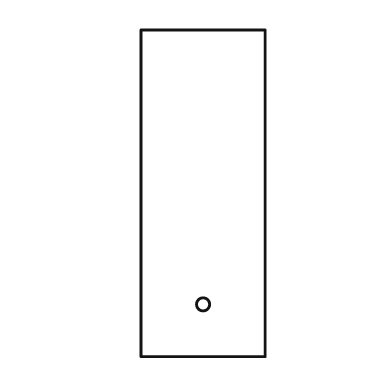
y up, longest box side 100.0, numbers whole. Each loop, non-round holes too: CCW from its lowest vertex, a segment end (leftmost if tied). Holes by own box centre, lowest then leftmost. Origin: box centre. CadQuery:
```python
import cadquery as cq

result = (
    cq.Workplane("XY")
    .moveTo(-19.0, -50.0)
    .lineTo(19.0, -50.0)
    .lineTo(19.0, 50.0)
    .lineTo(-19.0, 50.0)
    .close()
    .moveTo(0.0, -34.0)
    .circle(2.0)
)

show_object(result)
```